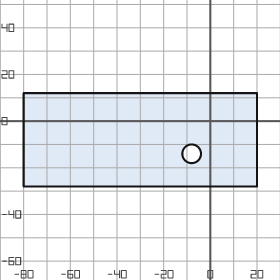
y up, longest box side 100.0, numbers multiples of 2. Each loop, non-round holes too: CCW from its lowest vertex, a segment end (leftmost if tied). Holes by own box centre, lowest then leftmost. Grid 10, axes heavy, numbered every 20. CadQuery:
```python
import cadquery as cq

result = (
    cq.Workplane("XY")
    .moveTo(-80.0, -28.0)
    .lineTo(20.0, -28.0)
    .lineTo(20.0, 12.0)
    .lineTo(-80.0, 12.0)
    .close()
    .moveTo(-8.0, -14.0)
    .circle(4.0)
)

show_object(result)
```